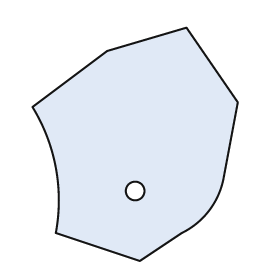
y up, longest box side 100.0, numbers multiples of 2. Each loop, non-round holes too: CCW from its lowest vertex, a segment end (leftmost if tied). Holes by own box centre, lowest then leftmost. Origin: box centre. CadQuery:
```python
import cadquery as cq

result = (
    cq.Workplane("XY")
    .moveTo(2.0, -50.0)
    .lineTo(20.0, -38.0)
    .threePointArc((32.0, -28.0), (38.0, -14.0))
    .lineTo(44.0, 18.0)
    .lineTo(22.0, 50.0)
    .lineTo(-12.0, 40.0)
    .lineTo(-44.0, 16.0)
    .threePointArc((-34.0, -10.0), (-34.0, -38.0))
    .close()
    .moveTo(0.0, -20.0)
    .circle(4.0)
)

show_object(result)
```